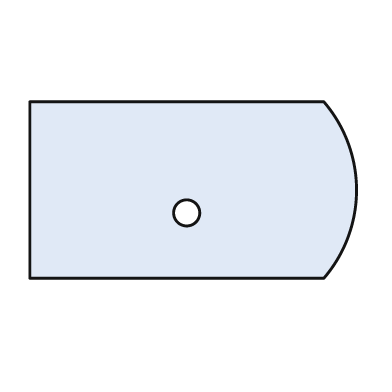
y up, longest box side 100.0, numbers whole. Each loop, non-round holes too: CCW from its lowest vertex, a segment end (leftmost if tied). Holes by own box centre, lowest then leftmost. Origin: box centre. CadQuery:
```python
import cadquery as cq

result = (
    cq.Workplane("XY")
    .moveTo(-50.0, -27.0)
    .lineTo(40.0, -27.0)
    .threePointArc((50.0, 0.0), (40.0, 27.0))
    .lineTo(-50.0, 27.0)
    .close()
    .moveTo(-2.0, -7.0)
    .circle(4.0)
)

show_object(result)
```